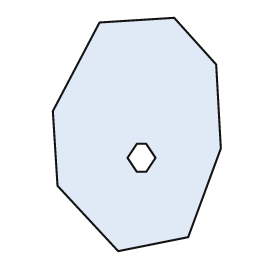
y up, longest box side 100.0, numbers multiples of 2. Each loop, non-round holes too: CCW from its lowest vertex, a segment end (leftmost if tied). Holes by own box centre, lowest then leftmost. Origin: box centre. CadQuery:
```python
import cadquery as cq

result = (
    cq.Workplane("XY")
    .moveTo(-8.0, -50.0)
    .lineTo(22.0, -44.0)
    .lineTo(36.0, -6.0)
    .lineTo(34.0, 30.0)
    .lineTo(16.0, 50.0)
    .lineTo(-16.0, 48.0)
    .lineTo(-36.0, 10.0)
    .lineTo(-34.0, -22.0)
    .close()
    .moveTo(0.0, -16.0)
    .lineTo(4.0, -16.0)
    .lineTo(8.0, -10.0)
    .lineTo(4.0, -4.0)
    .lineTo(0.0, -4.0)
    .lineTo(-4.0, -10.0)
    .close()
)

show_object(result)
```